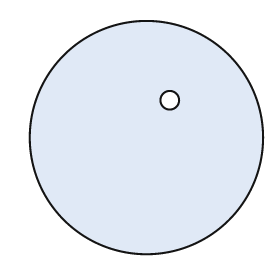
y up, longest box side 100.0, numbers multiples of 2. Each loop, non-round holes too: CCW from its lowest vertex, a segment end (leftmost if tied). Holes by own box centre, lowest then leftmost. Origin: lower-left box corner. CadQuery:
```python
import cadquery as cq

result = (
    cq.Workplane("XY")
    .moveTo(50.0, 50.0)
    .circle(50.0)
    .moveTo(60.0, 66.0)
    .circle(4.0)
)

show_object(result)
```